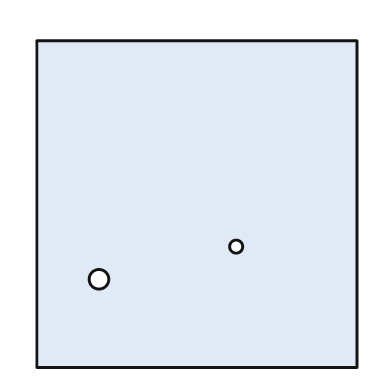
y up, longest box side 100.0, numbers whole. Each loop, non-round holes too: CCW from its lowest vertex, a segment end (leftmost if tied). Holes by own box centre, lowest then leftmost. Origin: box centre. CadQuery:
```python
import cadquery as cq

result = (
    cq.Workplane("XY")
    .moveTo(-49.0, -50.0)
    .lineTo(49.0, -50.0)
    .lineTo(49.0, 50.0)
    .lineTo(-49.0, 50.0)
    .close()
    .moveTo(-30.0, -23.0)
    .circle(3.0)
    .moveTo(12.0, -13.0)
    .circle(2.0)
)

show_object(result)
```